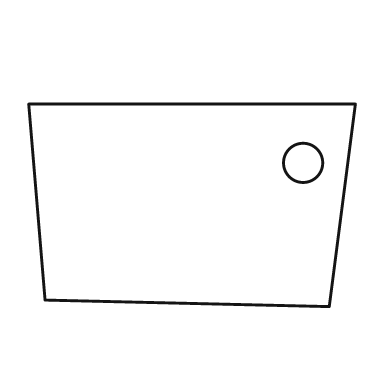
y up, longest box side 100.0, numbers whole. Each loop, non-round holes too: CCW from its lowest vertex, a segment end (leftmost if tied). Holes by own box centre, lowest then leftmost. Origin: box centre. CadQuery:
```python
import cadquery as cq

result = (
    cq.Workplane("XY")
    .moveTo(42.0, -31.0)
    .lineTo(50.0, 31.0)
    .lineTo(-50.0, 31.0)
    .lineTo(-45.0, -29.0)
    .close()
    .moveTo(34.0, 13.0)
    .circle(6.0)
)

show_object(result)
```